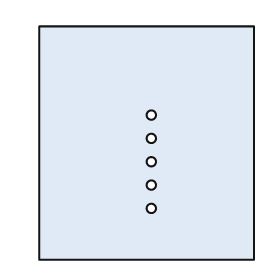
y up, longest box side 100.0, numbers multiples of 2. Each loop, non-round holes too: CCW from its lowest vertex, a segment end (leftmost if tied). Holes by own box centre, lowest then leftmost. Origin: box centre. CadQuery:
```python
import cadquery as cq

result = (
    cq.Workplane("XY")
    .moveTo(-46.0, -50.0)
    .lineTo(46.0, -50.0)
    .lineTo(46.0, 50.0)
    .lineTo(-46.0, 50.0)
    .close()
    .moveTo(2.0, -28.0)
    .circle(2.0)
    .moveTo(2.0, -18.0)
    .circle(2.0)
    .moveTo(2.0, -8.0)
    .circle(2.0)
    .moveTo(2.0, 2.0)
    .circle(2.0)
    .moveTo(2.0, 12.0)
    .circle(2.0)
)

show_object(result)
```